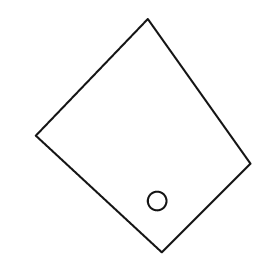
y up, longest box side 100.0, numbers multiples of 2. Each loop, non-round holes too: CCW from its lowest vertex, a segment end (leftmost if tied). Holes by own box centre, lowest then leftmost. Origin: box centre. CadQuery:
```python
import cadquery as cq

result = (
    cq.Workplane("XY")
    .moveTo(8.0, -50.0)
    .lineTo(46.0, -12.0)
    .lineTo(2.0, 50.0)
    .lineTo(-46.0, 0.0)
    .close()
    .moveTo(6.0, -28.0)
    .circle(4.0)
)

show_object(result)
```